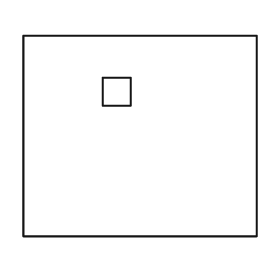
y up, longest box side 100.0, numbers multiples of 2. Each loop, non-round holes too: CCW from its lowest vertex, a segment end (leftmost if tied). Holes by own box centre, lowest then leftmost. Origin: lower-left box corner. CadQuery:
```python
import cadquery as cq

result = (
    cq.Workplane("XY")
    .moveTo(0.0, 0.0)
    .lineTo(100.0, 0.0)
    .lineTo(100.0, 86.0)
    .lineTo(0.0, 86.0)
    .close()
    .moveTo(34.0, 56.0)
    .lineTo(46.0, 56.0)
    .lineTo(46.0, 68.0)
    .lineTo(34.0, 68.0)
    .close()
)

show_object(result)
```